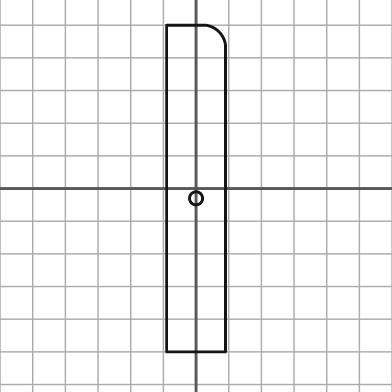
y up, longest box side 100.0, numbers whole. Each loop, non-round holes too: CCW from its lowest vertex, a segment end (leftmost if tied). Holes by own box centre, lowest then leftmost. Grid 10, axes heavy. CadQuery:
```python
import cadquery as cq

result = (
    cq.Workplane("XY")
    .moveTo(-9.0, -50.0)
    .lineTo(9.0, -50.0)
    .lineTo(9.0, 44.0)
    .threePointArc((7.0, 48.0), (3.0, 50.0))
    .lineTo(-9.0, 50.0)
    .close()
    .moveTo(0.0, -3.0)
    .circle(2.0)
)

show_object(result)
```